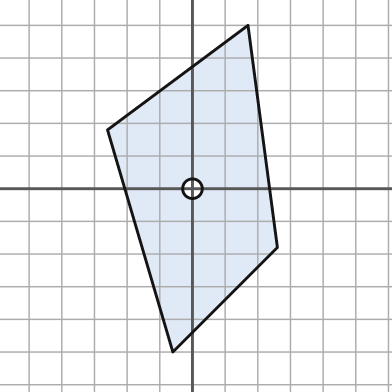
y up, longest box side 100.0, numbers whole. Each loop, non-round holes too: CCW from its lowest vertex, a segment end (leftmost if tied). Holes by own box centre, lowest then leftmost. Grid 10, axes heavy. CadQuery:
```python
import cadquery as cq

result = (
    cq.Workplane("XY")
    .moveTo(-6.0, -50.0)
    .lineTo(26.0, -18.0)
    .lineTo(17.0, 50.0)
    .lineTo(-26.0, 18.0)
    .close()
    .moveTo(0.0, 0.0)
    .circle(3.0)
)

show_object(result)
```